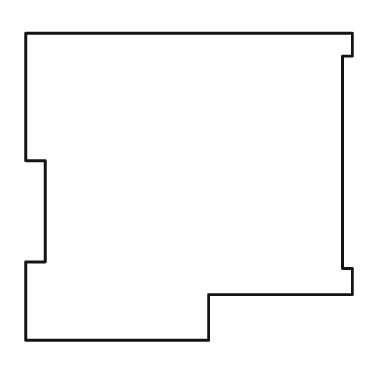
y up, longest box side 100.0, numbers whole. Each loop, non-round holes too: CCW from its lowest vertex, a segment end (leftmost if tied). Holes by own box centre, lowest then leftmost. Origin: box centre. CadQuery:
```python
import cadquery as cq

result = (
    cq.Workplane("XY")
    .moveTo(-50.0, -47.0)
    .lineTo(6.0, -47.0)
    .lineTo(6.0, -33.0)
    .lineTo(50.0, -33.0)
    .lineTo(50.0, -25.0)
    .lineTo(47.0, -25.0)
    .lineTo(47.0, 40.0)
    .lineTo(50.0, 40.0)
    .lineTo(50.0, 47.0)
    .lineTo(-50.0, 47.0)
    .lineTo(-50.0, 8.0)
    .lineTo(-44.0, 8.0)
    .lineTo(-44.0, -23.0)
    .lineTo(-50.0, -23.0)
    .close()
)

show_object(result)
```